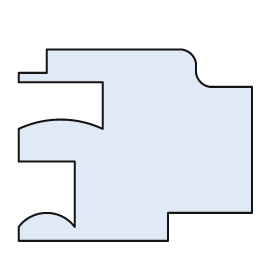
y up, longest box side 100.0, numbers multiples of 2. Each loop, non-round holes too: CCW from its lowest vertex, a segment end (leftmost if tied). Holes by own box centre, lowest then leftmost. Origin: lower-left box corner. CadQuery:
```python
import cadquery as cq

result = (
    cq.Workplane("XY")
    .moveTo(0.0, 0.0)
    .lineTo(64.0, 0.0)
    .lineTo(64.0, 12.0)
    .lineTo(100.0, 12.0)
    .lineTo(100.0, 66.0)
    .lineTo(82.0, 66.0)
    .threePointArc((78.0, 68.0), (76.0, 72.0))
    .lineTo(76.0, 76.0)
    .threePointArc((74.0, 80.0), (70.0, 82.0))
    .lineTo(12.0, 82.0)
    .lineTo(12.0, 72.0)
    .lineTo(0.0, 72.0)
    .lineTo(0.0, 68.0)
    .lineTo(36.0, 68.0)
    .lineTo(36.0, 48.0)
    .threePointArc((18.0, 52.0), (0.0, 48.0))
    .lineTo(0.0, 34.0)
    .lineTo(24.0, 34.0)
    .lineTo(24.0, 6.0)
    .threePointArc((12.0, 12.0), (0.0, 6.0))
    .close()
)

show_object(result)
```